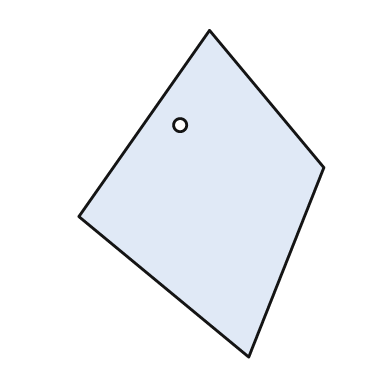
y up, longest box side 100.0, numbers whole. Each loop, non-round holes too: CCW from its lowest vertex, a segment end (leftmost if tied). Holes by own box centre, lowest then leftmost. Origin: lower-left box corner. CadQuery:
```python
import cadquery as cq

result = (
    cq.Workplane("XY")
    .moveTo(52.0, 0.0)
    .lineTo(75.0, 58.0)
    .lineTo(40.0, 100.0)
    .lineTo(0.0, 43.0)
    .close()
    .moveTo(31.0, 71.0)
    .circle(2.0)
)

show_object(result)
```